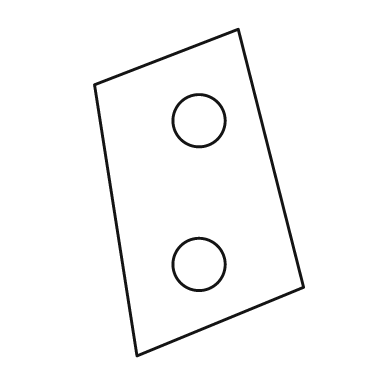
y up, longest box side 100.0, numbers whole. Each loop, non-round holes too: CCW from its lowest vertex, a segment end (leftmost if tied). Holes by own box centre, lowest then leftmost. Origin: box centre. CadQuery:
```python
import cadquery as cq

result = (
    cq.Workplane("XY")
    .moveTo(-19.0, -50.0)
    .lineTo(32.0, -29.0)
    .lineTo(12.0, 50.0)
    .lineTo(-32.0, 33.0)
    .close()
    .moveTo(0.0, -22.0)
    .circle(8.0)
    .moveTo(0.0, 22.0)
    .circle(8.0)
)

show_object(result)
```